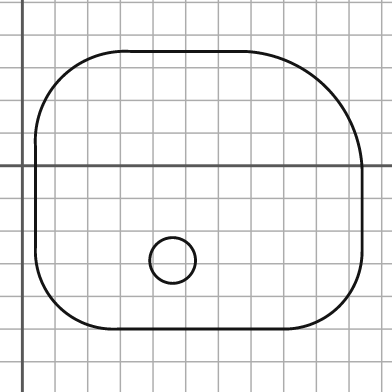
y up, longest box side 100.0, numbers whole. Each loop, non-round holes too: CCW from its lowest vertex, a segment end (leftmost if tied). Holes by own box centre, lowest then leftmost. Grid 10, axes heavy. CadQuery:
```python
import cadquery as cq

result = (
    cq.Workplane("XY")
    .moveTo(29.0, -50.0)
    .lineTo(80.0, -50.0)
    .threePointArc((97.0, -43.0), (104.0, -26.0))
    .lineTo(104.0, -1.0)
    .threePointArc((93.0, 24.0), (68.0, 35.0))
    .lineTo(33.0, 35.0)
    .threePointArc((12.0, 27.0), (4.0, 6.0))
    .lineTo(4.0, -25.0)
    .threePointArc((11.0, -43.0), (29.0, -50.0))
    .close()
    .moveTo(46.0, -29.0)
    .circle(7.0)
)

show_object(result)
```